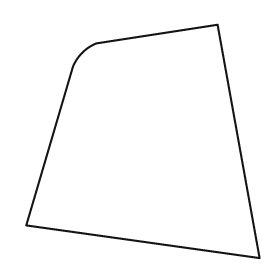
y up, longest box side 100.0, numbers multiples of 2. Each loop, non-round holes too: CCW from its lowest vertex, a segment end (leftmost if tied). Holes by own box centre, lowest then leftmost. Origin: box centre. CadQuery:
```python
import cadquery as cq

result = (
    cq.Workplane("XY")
    .moveTo(50.0, -50.0)
    .lineTo(32.0, 50.0)
    .lineTo(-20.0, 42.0)
    .threePointArc((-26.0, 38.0), (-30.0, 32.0))
    .lineTo(-50.0, -36.0)
    .close()
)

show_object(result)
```